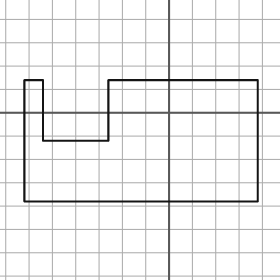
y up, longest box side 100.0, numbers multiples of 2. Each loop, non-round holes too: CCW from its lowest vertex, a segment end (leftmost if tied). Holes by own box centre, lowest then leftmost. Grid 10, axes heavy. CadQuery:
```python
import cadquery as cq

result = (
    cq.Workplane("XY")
    .moveTo(-62.0, -38.0)
    .lineTo(38.0, -38.0)
    .lineTo(38.0, 14.0)
    .lineTo(-26.0, 14.0)
    .lineTo(-26.0, -12.0)
    .lineTo(-54.0, -12.0)
    .lineTo(-54.0, 14.0)
    .lineTo(-62.0, 14.0)
    .close()
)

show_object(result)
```